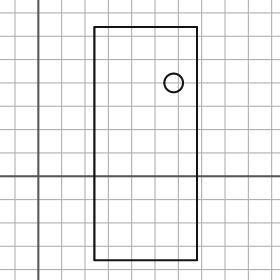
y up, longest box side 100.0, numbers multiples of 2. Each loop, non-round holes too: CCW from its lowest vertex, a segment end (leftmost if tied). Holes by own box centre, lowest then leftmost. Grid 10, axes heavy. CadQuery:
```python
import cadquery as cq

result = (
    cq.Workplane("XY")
    .moveTo(24.0, -36.0)
    .lineTo(68.0, -36.0)
    .lineTo(68.0, 64.0)
    .lineTo(24.0, 64.0)
    .close()
    .moveTo(58.0, 40.0)
    .circle(4.0)
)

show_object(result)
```